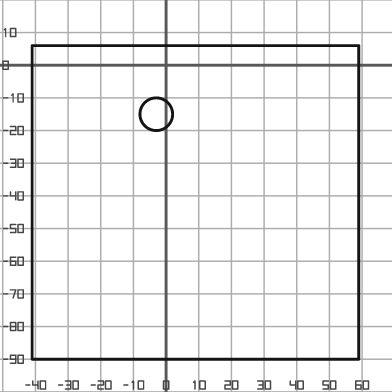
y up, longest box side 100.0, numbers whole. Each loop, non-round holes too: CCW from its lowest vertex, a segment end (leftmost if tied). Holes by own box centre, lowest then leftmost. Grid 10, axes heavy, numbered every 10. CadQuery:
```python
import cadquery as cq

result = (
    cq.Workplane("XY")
    .moveTo(-41.0, -90.0)
    .lineTo(59.0, -90.0)
    .lineTo(59.0, 6.0)
    .lineTo(-41.0, 6.0)
    .close()
    .moveTo(-3.0, -15.0)
    .circle(5.0)
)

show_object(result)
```